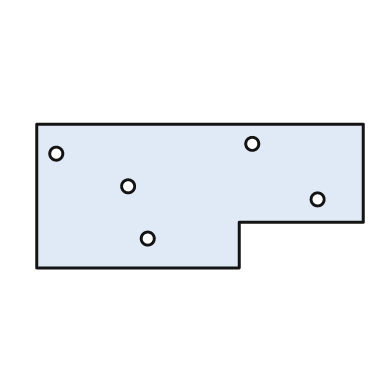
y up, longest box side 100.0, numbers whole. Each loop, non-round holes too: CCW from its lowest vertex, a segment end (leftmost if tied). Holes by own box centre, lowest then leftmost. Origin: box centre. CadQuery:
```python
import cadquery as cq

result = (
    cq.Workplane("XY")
    .moveTo(-50.0, -22.0)
    .lineTo(12.0, -22.0)
    .lineTo(12.0, -8.0)
    .lineTo(50.0, -8.0)
    .lineTo(50.0, 22.0)
    .lineTo(-50.0, 22.0)
    .close()
    .moveTo(-16.0, -13.0)
    .circle(2.0)
    .moveTo(36.0, -1.0)
    .circle(2.0)
    .moveTo(-22.0, 3.0)
    .circle(2.0)
    .moveTo(-44.0, 13.0)
    .circle(2.0)
    .moveTo(16.0, 16.0)
    .circle(2.0)
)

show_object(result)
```